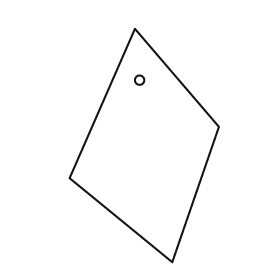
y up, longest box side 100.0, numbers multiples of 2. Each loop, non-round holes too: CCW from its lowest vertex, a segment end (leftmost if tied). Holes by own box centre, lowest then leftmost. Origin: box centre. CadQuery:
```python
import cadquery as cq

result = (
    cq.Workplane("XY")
    .moveTo(12.0, -50.0)
    .lineTo(32.0, 8.0)
    .lineTo(-4.0, 50.0)
    .lineTo(-32.0, -14.0)
    .close()
    .moveTo(-2.0, 28.0)
    .circle(2.0)
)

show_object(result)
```